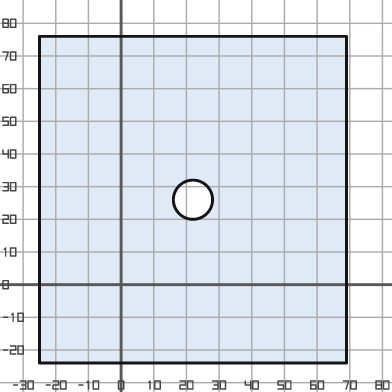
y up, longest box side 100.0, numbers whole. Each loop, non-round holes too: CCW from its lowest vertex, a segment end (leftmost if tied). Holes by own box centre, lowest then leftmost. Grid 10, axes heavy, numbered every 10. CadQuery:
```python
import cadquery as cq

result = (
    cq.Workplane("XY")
    .moveTo(-25.0, -24.0)
    .lineTo(69.0, -24.0)
    .lineTo(69.0, 76.0)
    .lineTo(-25.0, 76.0)
    .close()
    .moveTo(22.0, 26.0)
    .circle(6.0)
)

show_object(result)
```